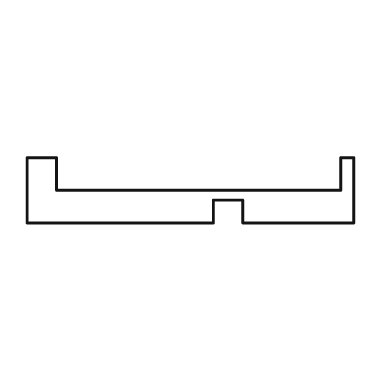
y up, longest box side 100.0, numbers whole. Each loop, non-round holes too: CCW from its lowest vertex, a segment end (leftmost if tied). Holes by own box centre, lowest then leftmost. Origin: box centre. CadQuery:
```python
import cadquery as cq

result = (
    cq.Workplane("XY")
    .moveTo(-50.0, -10.0)
    .lineTo(7.0, -10.0)
    .lineTo(7.0, -3.0)
    .lineTo(16.0, -3.0)
    .lineTo(16.0, -10.0)
    .lineTo(50.0, -10.0)
    .lineTo(50.0, 10.0)
    .lineTo(46.0, 10.0)
    .lineTo(46.0, 0.0)
    .lineTo(-41.0, 0.0)
    .lineTo(-41.0, 10.0)
    .lineTo(-50.0, 10.0)
    .close()
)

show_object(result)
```